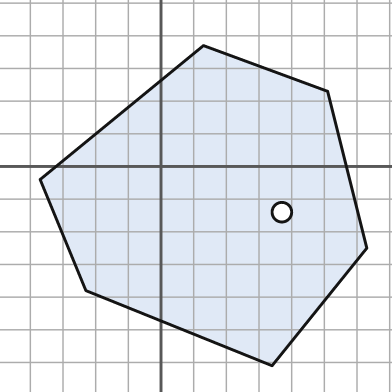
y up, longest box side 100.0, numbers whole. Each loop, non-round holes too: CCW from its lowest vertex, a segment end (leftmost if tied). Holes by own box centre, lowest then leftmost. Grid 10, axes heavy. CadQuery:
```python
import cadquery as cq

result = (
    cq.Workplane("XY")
    .moveTo(34.0, -61.0)
    .lineTo(63.0, -25.0)
    .lineTo(51.0, 23.0)
    .lineTo(13.0, 37.0)
    .lineTo(-37.0, -4.0)
    .lineTo(-23.0, -38.0)
    .close()
    .moveTo(37.0, -14.0)
    .circle(3.0)
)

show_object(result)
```